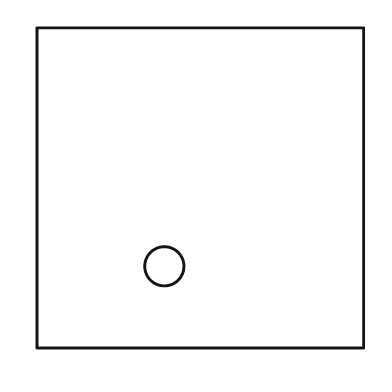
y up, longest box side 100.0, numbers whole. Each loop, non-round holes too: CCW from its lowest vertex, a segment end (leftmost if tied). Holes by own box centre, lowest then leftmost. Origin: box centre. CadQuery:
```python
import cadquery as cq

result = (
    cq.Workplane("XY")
    .moveTo(-50.0, -49.0)
    .lineTo(50.0, -49.0)
    .lineTo(50.0, 49.0)
    .lineTo(-50.0, 49.0)
    .close()
    .moveTo(-11.0, -24.0)
    .circle(6.0)
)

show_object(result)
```